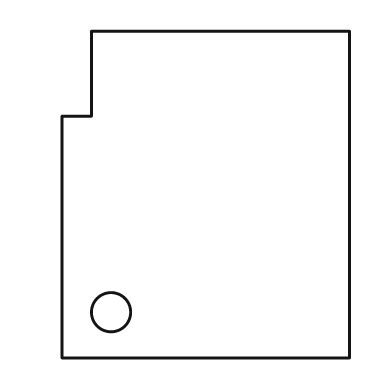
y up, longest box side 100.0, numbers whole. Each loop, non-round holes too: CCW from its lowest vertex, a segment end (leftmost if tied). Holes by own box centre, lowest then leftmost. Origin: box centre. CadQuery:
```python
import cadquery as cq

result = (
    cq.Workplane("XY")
    .moveTo(-44.0, -50.0)
    .lineTo(44.0, -50.0)
    .lineTo(44.0, 50.0)
    .lineTo(-35.0, 50.0)
    .lineTo(-35.0, 24.0)
    .lineTo(-44.0, 24.0)
    .close()
    .moveTo(-29.0, -36.0)
    .circle(6.0)
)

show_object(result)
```